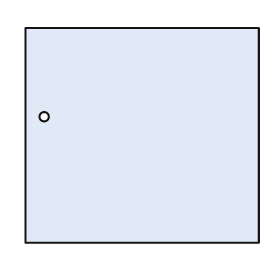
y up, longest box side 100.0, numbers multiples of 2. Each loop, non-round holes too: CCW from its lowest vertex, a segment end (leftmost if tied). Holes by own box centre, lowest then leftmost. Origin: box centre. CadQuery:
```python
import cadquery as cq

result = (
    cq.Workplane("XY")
    .moveTo(-50.0, -46.0)
    .lineTo(50.0, -46.0)
    .lineTo(50.0, 46.0)
    .lineTo(-50.0, 46.0)
    .close()
    .moveTo(-42.0, 8.0)
    .circle(2.0)
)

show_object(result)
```